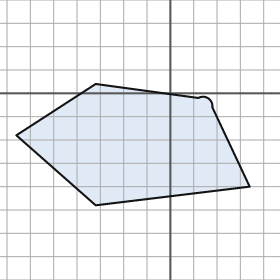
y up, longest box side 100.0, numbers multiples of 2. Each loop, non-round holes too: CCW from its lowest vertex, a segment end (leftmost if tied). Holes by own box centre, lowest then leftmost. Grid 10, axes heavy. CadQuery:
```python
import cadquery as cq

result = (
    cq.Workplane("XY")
    .moveTo(-32.0, -48.0)
    .lineTo(34.0, -40.0)
    .lineTo(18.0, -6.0)
    .threePointArc((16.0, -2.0), (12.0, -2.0))
    .lineTo(-32.0, 4.0)
    .lineTo(-66.0, -18.0)
    .close()
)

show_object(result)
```